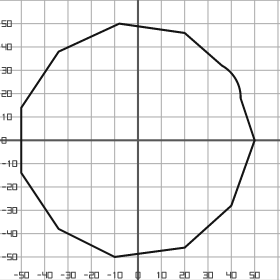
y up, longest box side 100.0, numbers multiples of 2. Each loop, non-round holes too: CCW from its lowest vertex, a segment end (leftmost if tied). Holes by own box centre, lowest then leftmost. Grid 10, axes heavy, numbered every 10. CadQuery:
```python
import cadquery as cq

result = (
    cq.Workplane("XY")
    .moveTo(-10.0, -50.0)
    .lineTo(20.0, -46.0)
    .lineTo(40.0, -28.0)
    .lineTo(50.0, 0.0)
    .lineTo(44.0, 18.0)
    .threePointArc((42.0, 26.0), (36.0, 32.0))
    .lineTo(20.0, 46.0)
    .lineTo(-8.0, 50.0)
    .lineTo(-34.0, 38.0)
    .lineTo(-50.0, 14.0)
    .lineTo(-50.0, -14.0)
    .lineTo(-34.0, -38.0)
    .close()
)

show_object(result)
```